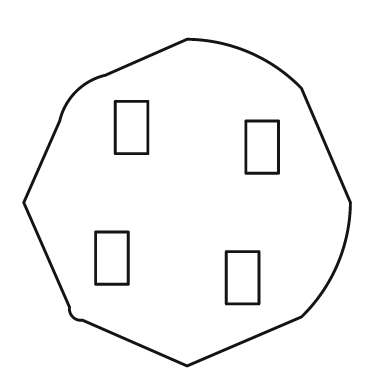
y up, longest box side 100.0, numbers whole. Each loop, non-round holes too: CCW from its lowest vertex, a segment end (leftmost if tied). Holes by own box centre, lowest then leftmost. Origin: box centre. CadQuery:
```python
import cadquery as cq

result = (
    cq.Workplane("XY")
    .moveTo(0.0, -50.0)
    .lineTo(35.0, -35.0)
    .threePointArc((46.0, -19.0), (50.0, 0.0))
    .lineTo(35.0, 35.0)
    .threePointArc((19.0, 46.0), (0.0, 50.0))
    .lineTo(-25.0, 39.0)
    .threePointArc((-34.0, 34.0), (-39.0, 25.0))
    .lineTo(-50.0, 0.0)
    .lineTo(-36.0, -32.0)
    .threePointArc((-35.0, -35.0), (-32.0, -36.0))
    .close()
    .moveTo(12.0, -31.0)
    .lineTo(22.0, -31.0)
    .lineTo(22.0, -15.0)
    .lineTo(12.0, -15.0)
    .close()
    .moveTo(-28.0, -25.0)
    .lineTo(-18.0, -25.0)
    .lineTo(-18.0, -9.0)
    .lineTo(-28.0, -9.0)
    .close()
    .moveTo(18.0, 9.0)
    .lineTo(28.0, 9.0)
    .lineTo(28.0, 25.0)
    .lineTo(18.0, 25.0)
    .close()
    .moveTo(-22.0, 15.0)
    .lineTo(-12.0, 15.0)
    .lineTo(-12.0, 31.0)
    .lineTo(-22.0, 31.0)
    .close()
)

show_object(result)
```